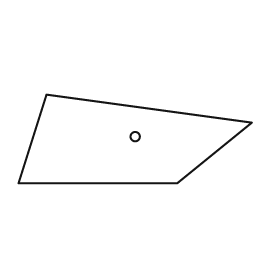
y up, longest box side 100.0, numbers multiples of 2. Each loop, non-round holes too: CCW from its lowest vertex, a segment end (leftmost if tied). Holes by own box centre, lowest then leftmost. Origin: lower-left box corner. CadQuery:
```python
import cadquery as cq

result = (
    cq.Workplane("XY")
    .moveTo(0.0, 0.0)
    .lineTo(68.0, 0.0)
    .lineTo(100.0, 26.0)
    .lineTo(12.0, 38.0)
    .close()
    .moveTo(50.0, 20.0)
    .circle(2.0)
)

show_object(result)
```